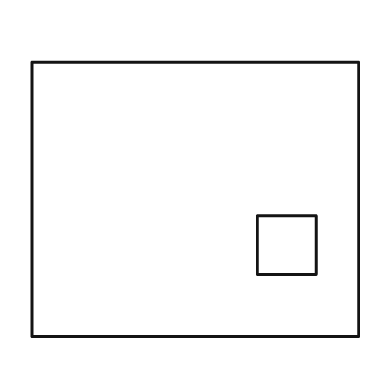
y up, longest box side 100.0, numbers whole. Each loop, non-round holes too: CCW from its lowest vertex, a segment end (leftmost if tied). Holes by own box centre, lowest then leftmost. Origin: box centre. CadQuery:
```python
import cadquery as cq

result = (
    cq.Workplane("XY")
    .moveTo(-50.0, -42.0)
    .lineTo(50.0, -42.0)
    .lineTo(50.0, 42.0)
    .lineTo(-50.0, 42.0)
    .close()
    .moveTo(19.0, -23.0)
    .lineTo(37.0, -23.0)
    .lineTo(37.0, -5.0)
    .lineTo(19.0, -5.0)
    .close()
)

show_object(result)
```